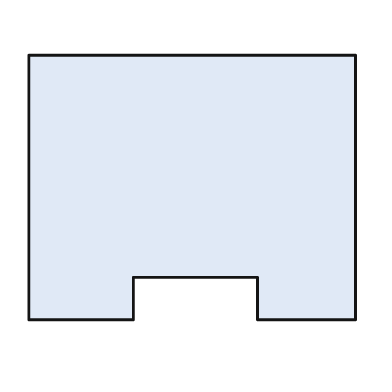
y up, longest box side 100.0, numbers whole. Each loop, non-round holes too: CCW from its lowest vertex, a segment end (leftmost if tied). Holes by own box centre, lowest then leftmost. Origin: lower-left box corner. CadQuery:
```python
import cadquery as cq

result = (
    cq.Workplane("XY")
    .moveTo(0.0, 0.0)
    .lineTo(32.0, 0.0)
    .lineTo(32.0, 13.0)
    .lineTo(70.0, 13.0)
    .lineTo(70.0, 0.0)
    .lineTo(100.0, 0.0)
    .lineTo(100.0, 81.0)
    .lineTo(0.0, 81.0)
    .close()
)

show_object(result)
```